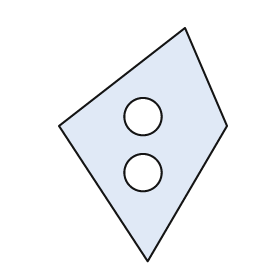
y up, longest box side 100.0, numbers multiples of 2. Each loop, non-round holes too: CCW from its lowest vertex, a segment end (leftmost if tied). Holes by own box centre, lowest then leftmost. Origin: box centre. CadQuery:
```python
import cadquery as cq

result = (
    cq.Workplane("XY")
    .moveTo(2.0, -50.0)
    .lineTo(36.0, 8.0)
    .lineTo(18.0, 50.0)
    .lineTo(-36.0, 8.0)
    .close()
    .moveTo(0.0, -12.0)
    .circle(8.0)
    .moveTo(0.0, 12.0)
    .circle(8.0)
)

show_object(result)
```